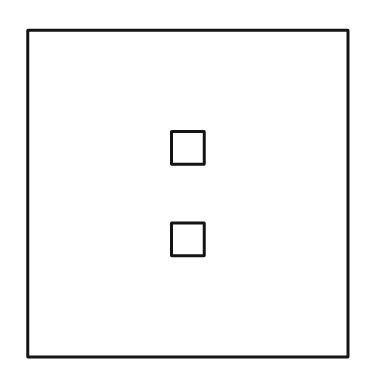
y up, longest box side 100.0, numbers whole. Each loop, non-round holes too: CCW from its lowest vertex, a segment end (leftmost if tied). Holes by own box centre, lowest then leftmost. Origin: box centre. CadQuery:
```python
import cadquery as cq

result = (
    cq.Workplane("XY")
    .moveTo(-49.0, -50.0)
    .lineTo(49.0, -50.0)
    .lineTo(49.0, 50.0)
    .lineTo(-49.0, 50.0)
    .close()
    .moveTo(-5.0, -19.0)
    .lineTo(5.0, -19.0)
    .lineTo(5.0, -9.0)
    .lineTo(-5.0, -9.0)
    .close()
    .moveTo(-5.0, 9.0)
    .lineTo(5.0, 9.0)
    .lineTo(5.0, 19.0)
    .lineTo(-5.0, 19.0)
    .close()
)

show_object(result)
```